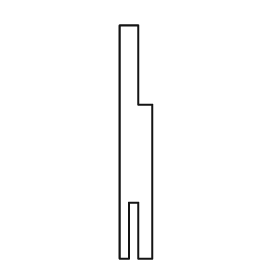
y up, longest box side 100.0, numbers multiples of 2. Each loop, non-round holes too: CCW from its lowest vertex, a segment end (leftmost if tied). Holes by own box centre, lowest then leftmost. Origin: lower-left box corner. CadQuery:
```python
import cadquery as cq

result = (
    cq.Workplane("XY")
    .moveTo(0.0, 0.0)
    .lineTo(4.0, 0.0)
    .lineTo(4.0, 24.0)
    .lineTo(8.0, 24.0)
    .lineTo(8.0, 0.0)
    .lineTo(14.0, 0.0)
    .lineTo(14.0, 66.0)
    .lineTo(8.0, 66.0)
    .lineTo(8.0, 100.0)
    .lineTo(0.0, 100.0)
    .close()
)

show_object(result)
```